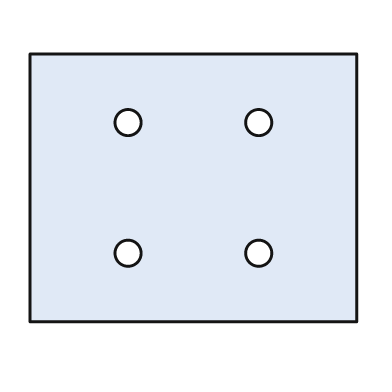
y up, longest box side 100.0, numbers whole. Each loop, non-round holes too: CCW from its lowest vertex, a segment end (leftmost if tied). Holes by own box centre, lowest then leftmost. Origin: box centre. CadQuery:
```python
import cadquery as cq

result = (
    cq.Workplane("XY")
    .moveTo(-50.0, -41.0)
    .lineTo(50.0, -41.0)
    .lineTo(50.0, 41.0)
    .lineTo(-50.0, 41.0)
    .close()
    .moveTo(-20.0, -20.0)
    .circle(4.0)
    .moveTo(20.0, -20.0)
    .circle(4.0)
    .moveTo(-20.0, 20.0)
    .circle(4.0)
    .moveTo(20.0, 20.0)
    .circle(4.0)
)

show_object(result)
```